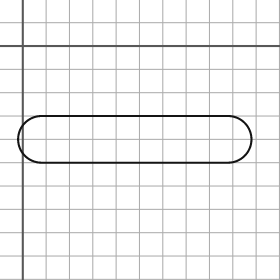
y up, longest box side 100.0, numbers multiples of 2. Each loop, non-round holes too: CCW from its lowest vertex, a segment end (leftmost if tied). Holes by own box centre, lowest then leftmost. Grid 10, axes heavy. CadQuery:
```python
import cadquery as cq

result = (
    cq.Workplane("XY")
    .moveTo(8.0, -50.0)
    .lineTo(88.0, -50.0)
    .threePointArc((98.0, -40.0), (88.0, -30.0))
    .lineTo(8.0, -30.0)
    .threePointArc((-2.0, -40.0), (8.0, -50.0))
    .close()
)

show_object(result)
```